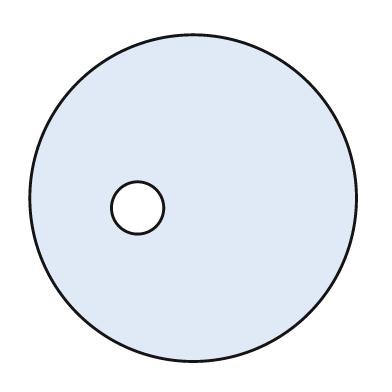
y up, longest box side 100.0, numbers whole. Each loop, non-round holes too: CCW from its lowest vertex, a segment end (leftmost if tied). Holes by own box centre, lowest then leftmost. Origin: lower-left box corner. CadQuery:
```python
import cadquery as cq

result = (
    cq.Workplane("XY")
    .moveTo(50.0, 50.0)
    .circle(50.0)
    .moveTo(33.0, 47.0)
    .circle(8.0)
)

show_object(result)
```